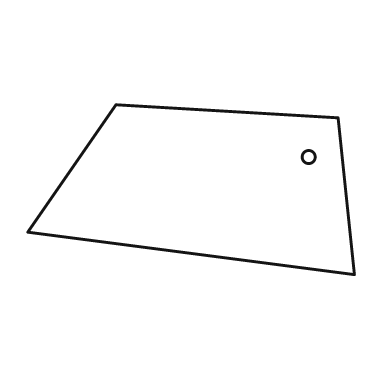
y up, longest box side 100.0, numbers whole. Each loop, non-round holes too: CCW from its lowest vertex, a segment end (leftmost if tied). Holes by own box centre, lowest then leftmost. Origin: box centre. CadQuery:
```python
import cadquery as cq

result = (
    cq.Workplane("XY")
    .moveTo(50.0, -26.0)
    .lineTo(45.0, 22.0)
    .lineTo(-23.0, 26.0)
    .lineTo(-50.0, -13.0)
    .close()
    .moveTo(36.0, 10.0)
    .circle(2.0)
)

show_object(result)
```